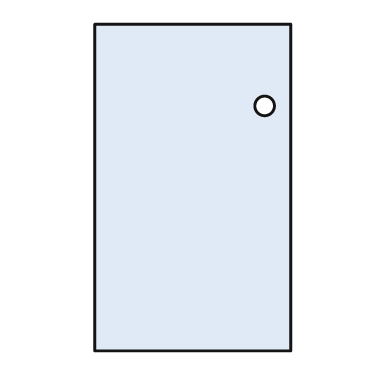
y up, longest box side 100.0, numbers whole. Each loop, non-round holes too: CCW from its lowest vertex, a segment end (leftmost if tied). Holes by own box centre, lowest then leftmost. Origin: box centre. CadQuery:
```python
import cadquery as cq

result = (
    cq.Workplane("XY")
    .moveTo(-30.0, -50.0)
    .lineTo(30.0, -50.0)
    .lineTo(30.0, 50.0)
    .lineTo(-30.0, 50.0)
    .close()
    .moveTo(22.0, 25.0)
    .circle(3.0)
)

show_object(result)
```